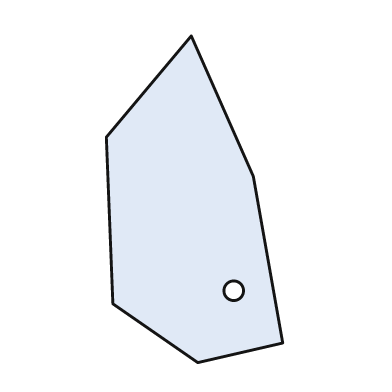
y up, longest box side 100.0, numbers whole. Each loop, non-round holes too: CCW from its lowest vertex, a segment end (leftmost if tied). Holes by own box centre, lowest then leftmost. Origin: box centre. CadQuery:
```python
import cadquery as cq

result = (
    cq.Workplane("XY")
    .moveTo(1.0, -50.0)
    .lineTo(27.0, -44.0)
    .lineTo(18.0, 7.0)
    .lineTo(-1.0, 50.0)
    .lineTo(-27.0, 19.0)
    .lineTo(-25.0, -32.0)
    .close()
    .moveTo(12.0, -28.0)
    .circle(3.0)
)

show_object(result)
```